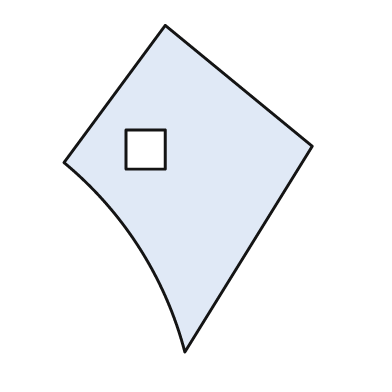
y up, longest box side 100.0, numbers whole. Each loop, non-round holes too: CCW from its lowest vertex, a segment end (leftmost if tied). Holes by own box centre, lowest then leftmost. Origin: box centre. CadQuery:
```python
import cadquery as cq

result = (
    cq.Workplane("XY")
    .moveTo(-1.0, -50.0)
    .lineTo(38.0, 13.0)
    .lineTo(-7.0, 50.0)
    .lineTo(-38.0, 8.0)
    .threePointArc((-15.0, -18.0), (-1.0, -50.0))
    .close()
    .moveTo(-19.0, 6.0)
    .lineTo(-7.0, 6.0)
    .lineTo(-7.0, 18.0)
    .lineTo(-19.0, 18.0)
    .close()
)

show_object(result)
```